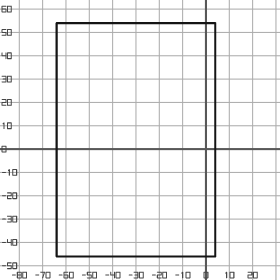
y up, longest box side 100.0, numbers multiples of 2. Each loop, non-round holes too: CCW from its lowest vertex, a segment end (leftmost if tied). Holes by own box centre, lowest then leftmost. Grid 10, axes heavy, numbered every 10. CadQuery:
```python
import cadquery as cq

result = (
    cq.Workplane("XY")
    .moveTo(-64.0, -46.0)
    .lineTo(4.0, -46.0)
    .lineTo(4.0, 54.0)
    .lineTo(-64.0, 54.0)
    .close()
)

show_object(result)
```